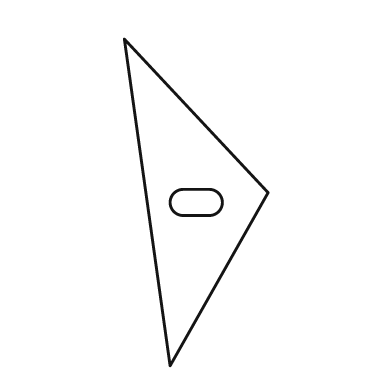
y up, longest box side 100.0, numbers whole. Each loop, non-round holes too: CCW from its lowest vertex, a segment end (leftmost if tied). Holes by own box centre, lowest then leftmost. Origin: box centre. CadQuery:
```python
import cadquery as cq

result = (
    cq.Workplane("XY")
    .moveTo(-8.0, -50.0)
    .lineTo(22.0, 3.0)
    .lineTo(-22.0, 50.0)
    .close()
    .moveTo(-4.0, -4.0)
    .lineTo(4.0, -4.0)
    .threePointArc((8.0, 0.0), (4.0, 4.0))
    .lineTo(-4.0, 4.0)
    .threePointArc((-8.0, 0.0), (-4.0, -4.0))
    .close()
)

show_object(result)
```